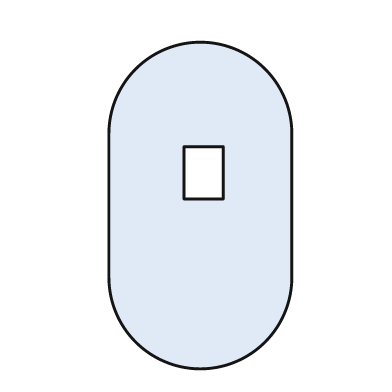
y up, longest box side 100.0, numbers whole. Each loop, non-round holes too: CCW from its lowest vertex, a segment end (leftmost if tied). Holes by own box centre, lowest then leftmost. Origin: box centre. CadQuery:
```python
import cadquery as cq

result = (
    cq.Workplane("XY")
    .moveTo(-28.0, -22.0)
    .threePointArc((0.0, -50.0), (28.0, -22.0))
    .lineTo(28.0, 22.0)
    .threePointArc((0.0, 50.0), (-28.0, 22.0))
    .close()
    .moveTo(-5.0, 2.0)
    .lineTo(7.0, 2.0)
    .lineTo(7.0, 18.0)
    .lineTo(-5.0, 18.0)
    .close()
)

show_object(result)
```